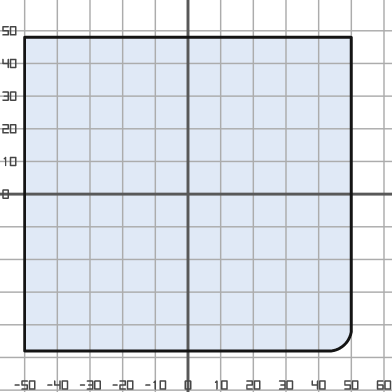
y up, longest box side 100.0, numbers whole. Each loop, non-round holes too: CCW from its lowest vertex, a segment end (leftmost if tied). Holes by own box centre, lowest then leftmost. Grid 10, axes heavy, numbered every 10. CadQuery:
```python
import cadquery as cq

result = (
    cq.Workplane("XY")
    .moveTo(-50.0, -48.0)
    .lineTo(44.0, -48.0)
    .threePointArc((48.0, -46.0), (50.0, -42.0))
    .lineTo(50.0, 48.0)
    .lineTo(-50.0, 48.0)
    .close()
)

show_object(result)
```